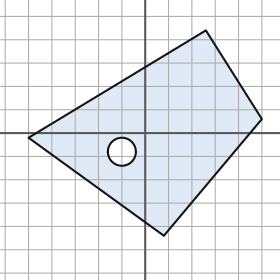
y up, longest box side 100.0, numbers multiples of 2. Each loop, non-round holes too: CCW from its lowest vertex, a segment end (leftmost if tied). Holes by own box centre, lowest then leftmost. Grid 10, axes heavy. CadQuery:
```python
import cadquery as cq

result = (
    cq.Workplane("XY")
    .moveTo(8.0, -44.0)
    .lineTo(50.0, 6.0)
    .lineTo(26.0, 44.0)
    .lineTo(-50.0, -2.0)
    .close()
    .moveTo(-10.0, -8.0)
    .circle(6.0)
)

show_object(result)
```